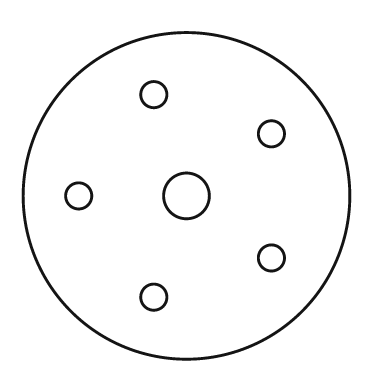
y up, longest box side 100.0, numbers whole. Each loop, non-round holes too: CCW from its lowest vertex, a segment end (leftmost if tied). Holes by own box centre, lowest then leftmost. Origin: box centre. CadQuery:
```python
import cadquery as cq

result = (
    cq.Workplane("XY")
    .moveTo(0.0, 0.0)
    .circle(50.0)
    .moveTo(-10.0, -31.0)
    .circle(4.0)
    .moveTo(26.0, -19.0)
    .circle(4.0)
    .moveTo(-33.0, 0.0)
    .circle(4.0)
    .moveTo(0.0, 0.0)
    .circle(7.0)
    .moveTo(26.0, 19.0)
    .circle(4.0)
    .moveTo(-10.0, 31.0)
    .circle(4.0)
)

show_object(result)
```